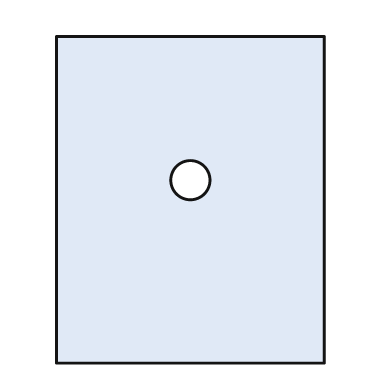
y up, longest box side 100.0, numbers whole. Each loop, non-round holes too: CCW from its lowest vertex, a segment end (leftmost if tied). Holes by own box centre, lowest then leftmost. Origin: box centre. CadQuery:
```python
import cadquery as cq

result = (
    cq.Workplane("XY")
    .moveTo(-41.0, -50.0)
    .lineTo(41.0, -50.0)
    .lineTo(41.0, 50.0)
    .lineTo(-41.0, 50.0)
    .close()
    .moveTo(0.0, 6.0)
    .circle(6.0)
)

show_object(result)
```